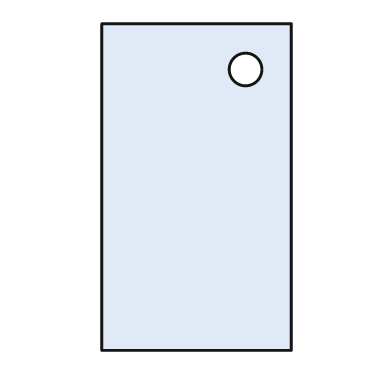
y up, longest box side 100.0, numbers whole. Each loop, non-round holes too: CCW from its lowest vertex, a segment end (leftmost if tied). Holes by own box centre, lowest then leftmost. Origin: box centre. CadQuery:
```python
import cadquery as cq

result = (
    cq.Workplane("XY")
    .moveTo(-29.0, -50.0)
    .lineTo(29.0, -50.0)
    .lineTo(29.0, 50.0)
    .lineTo(-29.0, 50.0)
    .close()
    .moveTo(15.0, 36.0)
    .circle(5.0)
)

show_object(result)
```